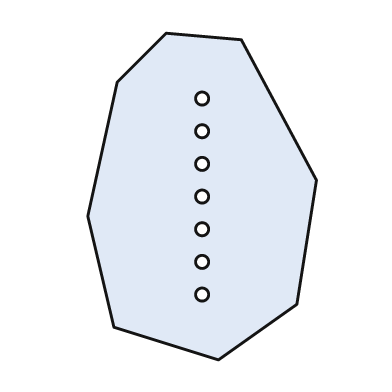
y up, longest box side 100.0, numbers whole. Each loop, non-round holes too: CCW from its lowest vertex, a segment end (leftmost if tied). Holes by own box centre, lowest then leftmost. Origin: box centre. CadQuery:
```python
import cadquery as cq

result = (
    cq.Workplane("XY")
    .moveTo(5.0, -50.0)
    .lineTo(29.0, -33.0)
    .lineTo(35.0, 5.0)
    .lineTo(12.0, 48.0)
    .lineTo(-11.0, 50.0)
    .lineTo(-26.0, 35.0)
    .lineTo(-35.0, -6.0)
    .lineTo(-27.0, -40.0)
    .close()
    .moveTo(0.0, -30.0)
    .circle(2.0)
    .moveTo(0.0, -20.0)
    .circle(2.0)
    .moveTo(0.0, -10.0)
    .circle(2.0)
    .moveTo(0.0, 0.0)
    .circle(2.0)
    .moveTo(0.0, 10.0)
    .circle(2.0)
    .moveTo(0.0, 20.0)
    .circle(2.0)
    .moveTo(0.0, 30.0)
    .circle(2.0)
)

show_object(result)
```